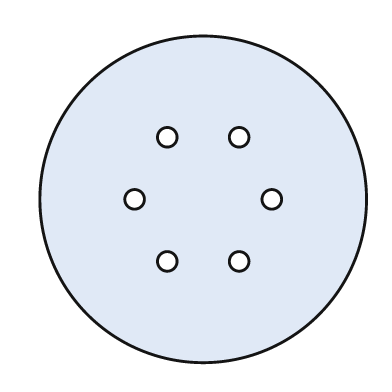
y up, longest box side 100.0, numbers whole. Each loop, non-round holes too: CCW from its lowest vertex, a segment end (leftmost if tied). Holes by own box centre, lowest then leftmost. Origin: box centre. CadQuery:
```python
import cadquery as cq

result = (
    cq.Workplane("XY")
    .moveTo(0.0, 0.0)
    .circle(50.0)
    .moveTo(-11.0, -19.0)
    .circle(3.0)
    .moveTo(11.0, -19.0)
    .circle(3.0)
    .moveTo(-21.0, 0.0)
    .circle(3.0)
    .moveTo(21.0, 0.0)
    .circle(3.0)
    .moveTo(-11.0, 19.0)
    .circle(3.0)
    .moveTo(11.0, 19.0)
    .circle(3.0)
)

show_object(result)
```